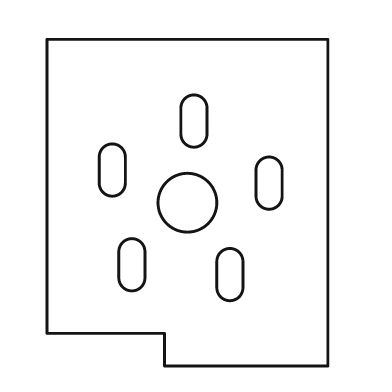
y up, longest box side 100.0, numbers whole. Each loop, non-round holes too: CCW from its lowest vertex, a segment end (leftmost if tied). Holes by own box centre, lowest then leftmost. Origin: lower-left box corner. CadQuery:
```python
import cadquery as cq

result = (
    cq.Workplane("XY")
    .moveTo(36.0, 0.0)
    .lineTo(86.0, 0.0)
    .lineTo(86.0, 100.0)
    .lineTo(0.0, 100.0)
    .lineTo(0.0, 10.0)
    .lineTo(36.0, 10.0)
    .close()
    .moveTo(52.0, 24.0)
    .threePointArc((56.0, 20.0), (60.0, 24.0))
    .lineTo(60.0, 32.0)
    .threePointArc((56.0, 36.0), (52.0, 32.0))
    .close()
    .moveTo(22.0, 27.0)
    .threePointArc((26.0, 23.0), (30.0, 27.0))
    .lineTo(30.0, 35.0)
    .threePointArc((26.0, 39.0), (22.0, 35.0))
    .close()
    .moveTo(43.0, 50.0)
    .circle(9.0)
    .moveTo(64.0, 52.0)
    .threePointArc((68.0, 48.0), (72.0, 52.0))
    .lineTo(72.0, 60.0)
    .threePointArc((68.0, 64.0), (64.0, 60.0))
    .close()
    .moveTo(16.0, 56.0)
    .threePointArc((20.0, 52.0), (24.0, 56.0))
    .lineTo(24.0, 64.0)
    .threePointArc((20.0, 68.0), (16.0, 64.0))
    .close()
    .moveTo(41.0, 71.0)
    .threePointArc((45.0, 67.0), (49.0, 71.0))
    .lineTo(49.0, 79.0)
    .threePointArc((45.0, 83.0), (41.0, 79.0))
    .close()
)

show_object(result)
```